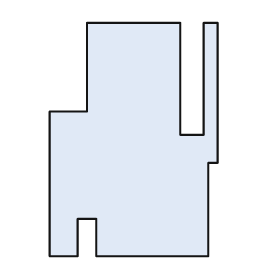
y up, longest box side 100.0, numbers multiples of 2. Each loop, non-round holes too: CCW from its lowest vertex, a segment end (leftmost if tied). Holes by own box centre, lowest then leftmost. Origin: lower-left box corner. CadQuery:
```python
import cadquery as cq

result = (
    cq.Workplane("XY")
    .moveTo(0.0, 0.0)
    .lineTo(12.0, 0.0)
    .lineTo(12.0, 16.0)
    .lineTo(20.0, 16.0)
    .lineTo(20.0, 0.0)
    .lineTo(68.0, 0.0)
    .lineTo(68.0, 40.0)
    .lineTo(72.0, 40.0)
    .lineTo(72.0, 100.0)
    .lineTo(66.0, 100.0)
    .lineTo(66.0, 52.0)
    .lineTo(56.0, 52.0)
    .lineTo(56.0, 100.0)
    .lineTo(16.0, 100.0)
    .lineTo(16.0, 62.0)
    .lineTo(0.0, 62.0)
    .close()
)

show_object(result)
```